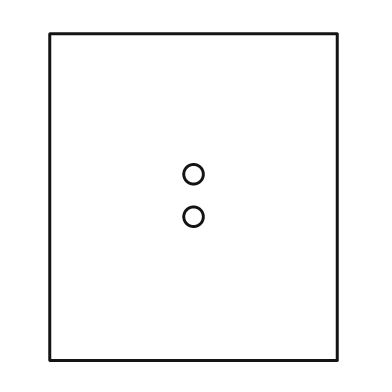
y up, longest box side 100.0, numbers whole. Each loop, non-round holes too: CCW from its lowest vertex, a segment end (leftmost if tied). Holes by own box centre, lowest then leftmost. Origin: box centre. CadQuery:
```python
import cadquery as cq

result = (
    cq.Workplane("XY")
    .moveTo(-44.0, -50.0)
    .lineTo(44.0, -50.0)
    .lineTo(44.0, 50.0)
    .lineTo(-44.0, 50.0)
    .close()
    .moveTo(0.0, -6.0)
    .circle(3.0)
    .moveTo(0.0, 7.0)
    .circle(3.0)
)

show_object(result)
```